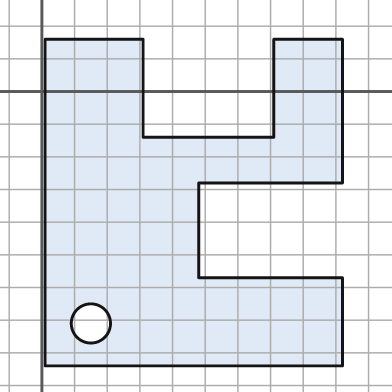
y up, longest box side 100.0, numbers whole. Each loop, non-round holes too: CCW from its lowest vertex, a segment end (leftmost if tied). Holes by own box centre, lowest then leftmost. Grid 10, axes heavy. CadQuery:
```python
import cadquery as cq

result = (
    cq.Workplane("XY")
    .moveTo(1.0, -84.0)
    .lineTo(92.0, -84.0)
    .lineTo(92.0, -57.0)
    .lineTo(48.0, -57.0)
    .lineTo(48.0, -28.0)
    .lineTo(92.0, -28.0)
    .lineTo(92.0, 16.0)
    .lineTo(71.0, 16.0)
    .lineTo(71.0, -14.0)
    .lineTo(31.0, -14.0)
    .lineTo(31.0, 16.0)
    .lineTo(1.0, 16.0)
    .close()
    .moveTo(15.0, -71.0)
    .circle(6.0)
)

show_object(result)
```